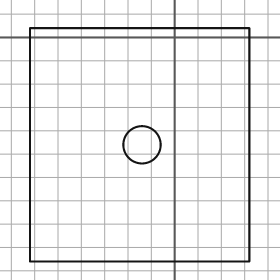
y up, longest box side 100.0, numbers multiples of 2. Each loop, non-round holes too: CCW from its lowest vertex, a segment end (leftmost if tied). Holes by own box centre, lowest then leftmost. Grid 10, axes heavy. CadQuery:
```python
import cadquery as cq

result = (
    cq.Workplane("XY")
    .moveTo(-62.0, -96.0)
    .lineTo(32.0, -96.0)
    .lineTo(32.0, 4.0)
    .lineTo(-62.0, 4.0)
    .close()
    .moveTo(-14.0, -46.0)
    .circle(8.0)
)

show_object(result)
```